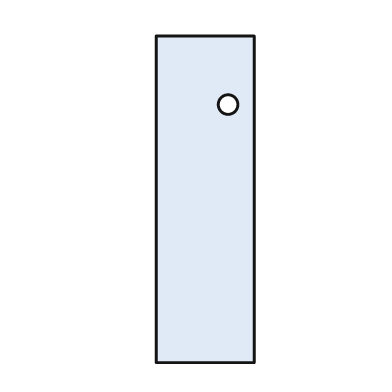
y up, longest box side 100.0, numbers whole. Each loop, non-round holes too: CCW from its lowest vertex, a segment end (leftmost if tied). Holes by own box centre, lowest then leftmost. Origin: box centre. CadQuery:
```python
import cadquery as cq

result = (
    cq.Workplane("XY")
    .moveTo(-15.0, -50.0)
    .lineTo(15.0, -50.0)
    .lineTo(15.0, 50.0)
    .lineTo(-15.0, 50.0)
    .close()
    .moveTo(7.0, 29.0)
    .circle(3.0)
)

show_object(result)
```